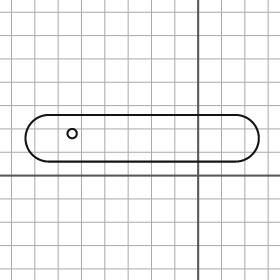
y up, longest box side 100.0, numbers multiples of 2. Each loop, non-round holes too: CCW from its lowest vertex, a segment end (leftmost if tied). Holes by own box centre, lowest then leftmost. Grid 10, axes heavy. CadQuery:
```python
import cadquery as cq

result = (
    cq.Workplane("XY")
    .moveTo(-64.0, 6.0)
    .lineTo(16.0, 6.0)
    .threePointArc((26.0, 16.0), (16.0, 26.0))
    .lineTo(-64.0, 26.0)
    .threePointArc((-74.0, 16.0), (-64.0, 6.0))
    .close()
    .moveTo(-54.0, 18.0)
    .circle(2.0)
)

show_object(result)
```